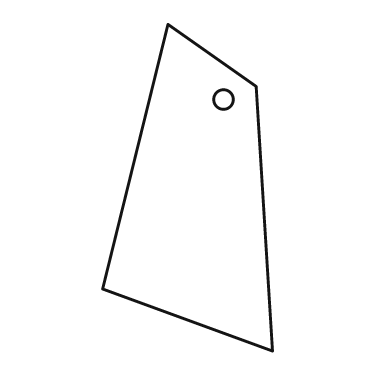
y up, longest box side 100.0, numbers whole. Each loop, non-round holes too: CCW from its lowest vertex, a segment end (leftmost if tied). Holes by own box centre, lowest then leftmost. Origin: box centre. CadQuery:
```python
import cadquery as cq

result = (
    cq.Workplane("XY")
    .moveTo(26.0, -50.0)
    .lineTo(21.0, 31.0)
    .lineTo(-6.0, 50.0)
    .lineTo(-26.0, -31.0)
    .close()
    .moveTo(11.0, 27.0)
    .circle(3.0)
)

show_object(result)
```